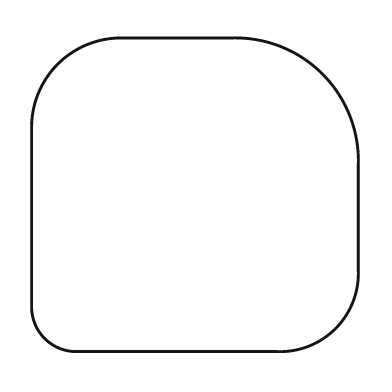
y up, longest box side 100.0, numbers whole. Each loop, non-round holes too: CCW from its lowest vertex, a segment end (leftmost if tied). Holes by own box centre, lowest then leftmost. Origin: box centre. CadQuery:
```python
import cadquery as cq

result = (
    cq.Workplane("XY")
    .moveTo(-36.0, -48.0)
    .lineTo(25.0, -48.0)
    .threePointArc((43.0, -41.0), (50.0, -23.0))
    .lineTo(50.0, 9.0)
    .threePointArc((39.0, 37.0), (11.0, 48.0))
    .lineTo(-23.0, 48.0)
    .threePointArc((-42.0, 40.0), (-50.0, 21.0))
    .lineTo(-50.0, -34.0)
    .threePointArc((-46.0, -44.0), (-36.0, -48.0))
    .close()
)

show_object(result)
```